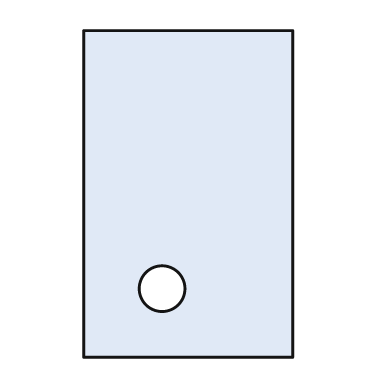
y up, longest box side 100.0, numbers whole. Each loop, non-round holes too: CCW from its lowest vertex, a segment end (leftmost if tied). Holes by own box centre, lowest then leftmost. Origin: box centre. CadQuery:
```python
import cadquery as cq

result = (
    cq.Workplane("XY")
    .moveTo(-32.0, -50.0)
    .lineTo(32.0, -50.0)
    .lineTo(32.0, 50.0)
    .lineTo(-32.0, 50.0)
    .close()
    .moveTo(-8.0, -29.0)
    .circle(7.0)
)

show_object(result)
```